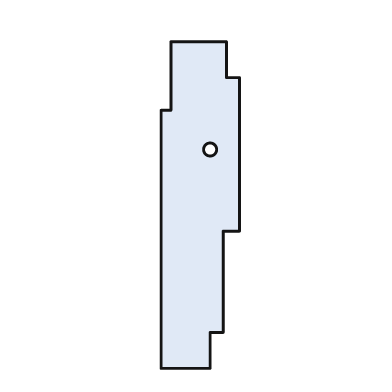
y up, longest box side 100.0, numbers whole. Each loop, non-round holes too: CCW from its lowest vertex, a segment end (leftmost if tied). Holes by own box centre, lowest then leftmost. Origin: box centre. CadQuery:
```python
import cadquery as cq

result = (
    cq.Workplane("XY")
    .moveTo(-12.0, -50.0)
    .lineTo(3.0, -50.0)
    .lineTo(3.0, -39.0)
    .lineTo(7.0, -39.0)
    .lineTo(7.0, -8.0)
    .lineTo(12.0, -8.0)
    .lineTo(12.0, 39.0)
    .lineTo(8.0, 39.0)
    .lineTo(8.0, 50.0)
    .lineTo(-9.0, 50.0)
    .lineTo(-9.0, 29.0)
    .lineTo(-12.0, 29.0)
    .close()
    .moveTo(3.0, 17.0)
    .circle(2.0)
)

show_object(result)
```